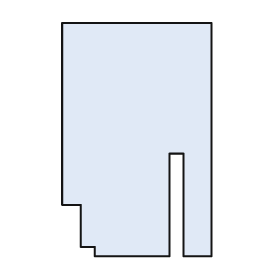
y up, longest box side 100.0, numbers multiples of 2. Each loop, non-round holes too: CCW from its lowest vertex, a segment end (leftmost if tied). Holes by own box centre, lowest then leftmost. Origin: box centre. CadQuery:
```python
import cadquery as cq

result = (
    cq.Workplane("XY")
    .moveTo(-18.0, -50.0)
    .lineTo(14.0, -50.0)
    .lineTo(14.0, -6.0)
    .lineTo(20.0, -6.0)
    .lineTo(20.0, -50.0)
    .lineTo(32.0, -50.0)
    .lineTo(32.0, 50.0)
    .lineTo(-32.0, 50.0)
    .lineTo(-32.0, -28.0)
    .lineTo(-24.0, -28.0)
    .lineTo(-24.0, -46.0)
    .lineTo(-18.0, -46.0)
    .close()
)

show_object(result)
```